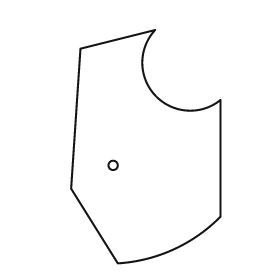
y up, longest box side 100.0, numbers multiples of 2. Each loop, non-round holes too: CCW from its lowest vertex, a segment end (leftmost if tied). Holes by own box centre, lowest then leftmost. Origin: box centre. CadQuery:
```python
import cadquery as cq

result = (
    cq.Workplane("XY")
    .moveTo(-12.0, -50.0)
    .threePointArc((12.0, -44.0), (32.0, -30.0))
    .lineTo(32.0, 20.0)
    .threePointArc((4.0, 22.0), (4.0, 50.0))
    .lineTo(-28.0, 42.0)
    .lineTo(-32.0, -18.0)
    .close()
    .moveTo(-14.0, -8.0)
    .circle(2.0)
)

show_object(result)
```